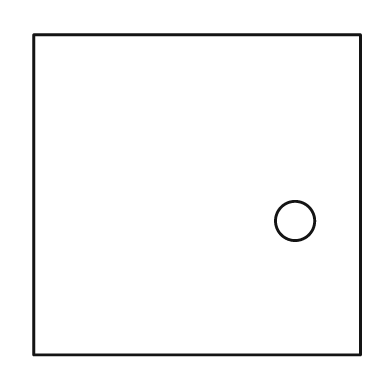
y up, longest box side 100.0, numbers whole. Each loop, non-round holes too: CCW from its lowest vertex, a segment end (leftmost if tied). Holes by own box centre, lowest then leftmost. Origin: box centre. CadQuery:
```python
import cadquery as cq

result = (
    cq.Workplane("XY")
    .moveTo(-50.0, -49.0)
    .lineTo(50.0, -49.0)
    .lineTo(50.0, 49.0)
    .lineTo(-50.0, 49.0)
    .close()
    .moveTo(30.0, -8.0)
    .circle(6.0)
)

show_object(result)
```